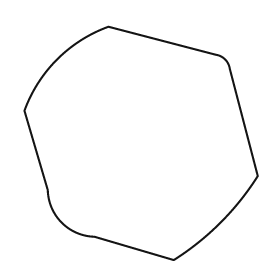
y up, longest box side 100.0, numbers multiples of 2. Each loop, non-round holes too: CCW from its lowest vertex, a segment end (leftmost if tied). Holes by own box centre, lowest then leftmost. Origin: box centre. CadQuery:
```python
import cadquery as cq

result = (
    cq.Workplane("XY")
    .moveTo(14.0, -50.0)
    .threePointArc((34.0, -34.0), (50.0, -14.0))
    .lineTo(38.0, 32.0)
    .threePointArc((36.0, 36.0), (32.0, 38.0))
    .lineTo(-14.0, 50.0)
    .threePointArc((-36.0, 36.0), (-50.0, 14.0))
    .lineTo(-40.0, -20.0)
    .threePointArc((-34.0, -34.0), (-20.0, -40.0))
    .close()
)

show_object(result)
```